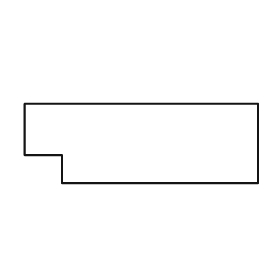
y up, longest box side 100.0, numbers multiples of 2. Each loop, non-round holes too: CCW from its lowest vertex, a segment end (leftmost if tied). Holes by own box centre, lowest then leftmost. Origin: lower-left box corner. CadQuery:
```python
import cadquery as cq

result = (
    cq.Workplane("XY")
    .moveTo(16.0, 0.0)
    .lineTo(100.0, 0.0)
    .lineTo(100.0, 34.0)
    .lineTo(0.0, 34.0)
    .lineTo(0.0, 12.0)
    .lineTo(16.0, 12.0)
    .close()
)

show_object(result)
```